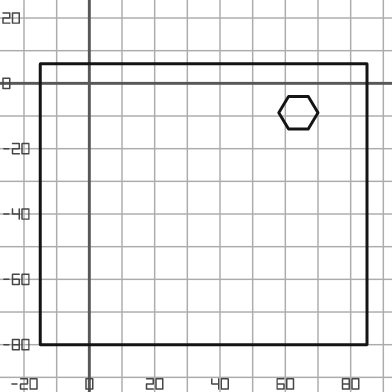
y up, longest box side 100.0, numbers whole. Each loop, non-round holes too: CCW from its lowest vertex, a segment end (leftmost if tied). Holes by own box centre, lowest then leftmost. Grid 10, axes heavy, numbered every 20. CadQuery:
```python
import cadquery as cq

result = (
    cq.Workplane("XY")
    .moveTo(-15.0, -80.0)
    .lineTo(85.0, -80.0)
    .lineTo(85.0, 6.0)
    .lineTo(-15.0, 6.0)
    .close()
    .moveTo(61.0, -14.0)
    .lineTo(67.0, -14.0)
    .lineTo(70.0, -9.0)
    .lineTo(67.0, -4.0)
    .lineTo(61.0, -4.0)
    .lineTo(58.0, -9.0)
    .close()
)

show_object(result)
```